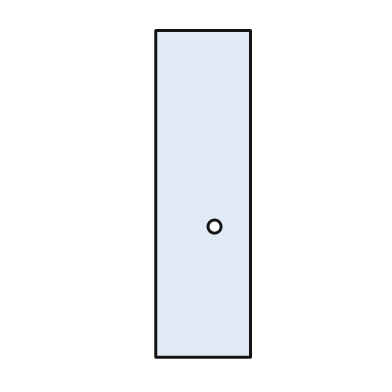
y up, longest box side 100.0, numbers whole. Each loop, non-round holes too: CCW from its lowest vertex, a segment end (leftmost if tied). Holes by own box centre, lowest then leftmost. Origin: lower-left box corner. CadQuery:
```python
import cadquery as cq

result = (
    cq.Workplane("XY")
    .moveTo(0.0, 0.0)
    .lineTo(29.0, 0.0)
    .lineTo(29.0, 100.0)
    .lineTo(0.0, 100.0)
    .close()
    .moveTo(18.0, 40.0)
    .circle(2.0)
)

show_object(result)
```